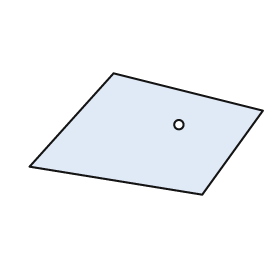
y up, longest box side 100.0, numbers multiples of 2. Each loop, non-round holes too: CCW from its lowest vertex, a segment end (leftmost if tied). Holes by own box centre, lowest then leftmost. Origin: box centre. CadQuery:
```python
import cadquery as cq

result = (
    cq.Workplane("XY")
    .moveTo(24.0, -26.0)
    .lineTo(50.0, 10.0)
    .lineTo(-14.0, 26.0)
    .lineTo(-50.0, -14.0)
    .close()
    .moveTo(14.0, 4.0)
    .circle(2.0)
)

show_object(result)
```